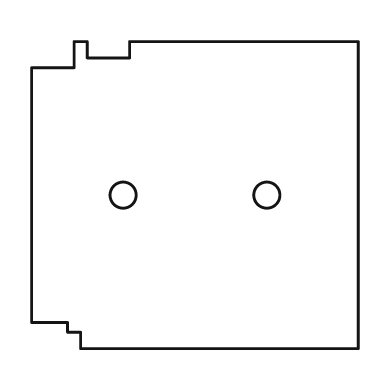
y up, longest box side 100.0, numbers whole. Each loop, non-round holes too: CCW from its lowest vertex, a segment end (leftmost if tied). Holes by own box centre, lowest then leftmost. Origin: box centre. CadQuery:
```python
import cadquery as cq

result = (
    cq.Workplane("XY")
    .moveTo(-35.0, -47.0)
    .lineTo(50.0, -47.0)
    .lineTo(50.0, 47.0)
    .lineTo(-20.0, 47.0)
    .lineTo(-20.0, 42.0)
    .lineTo(-33.0, 42.0)
    .lineTo(-33.0, 47.0)
    .lineTo(-37.0, 47.0)
    .lineTo(-37.0, 39.0)
    .lineTo(-50.0, 39.0)
    .lineTo(-50.0, -39.0)
    .lineTo(-39.0, -39.0)
    .lineTo(-39.0, -42.0)
    .lineTo(-35.0, -42.0)
    .close()
    .moveTo(-22.0, 0.0)
    .circle(4.0)
    .moveTo(22.0, 0.0)
    .circle(4.0)
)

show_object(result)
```